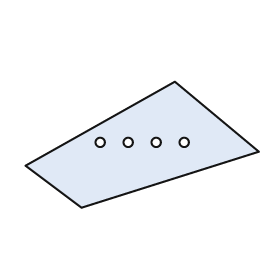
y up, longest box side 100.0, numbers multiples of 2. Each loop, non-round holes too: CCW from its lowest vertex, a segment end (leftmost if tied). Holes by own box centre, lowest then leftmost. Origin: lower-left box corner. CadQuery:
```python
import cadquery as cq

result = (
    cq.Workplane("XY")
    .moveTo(24.0, 0.0)
    .lineTo(100.0, 24.0)
    .lineTo(64.0, 54.0)
    .lineTo(0.0, 18.0)
    .close()
    .moveTo(32.0, 28.0)
    .circle(2.0)
    .moveTo(44.0, 28.0)
    .circle(2.0)
    .moveTo(56.0, 28.0)
    .circle(2.0)
    .moveTo(68.0, 28.0)
    .circle(2.0)
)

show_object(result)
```